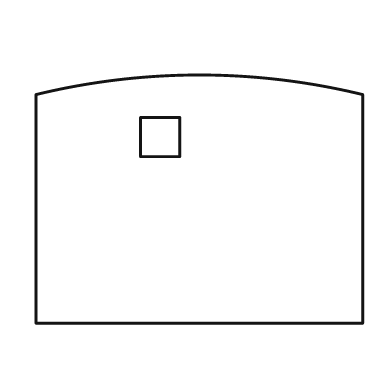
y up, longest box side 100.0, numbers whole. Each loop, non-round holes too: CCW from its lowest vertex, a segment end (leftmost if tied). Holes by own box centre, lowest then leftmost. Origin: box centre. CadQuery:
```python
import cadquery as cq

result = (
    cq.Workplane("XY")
    .moveTo(-50.0, -38.0)
    .lineTo(50.0, -38.0)
    .lineTo(50.0, 32.0)
    .threePointArc((0.0, 38.0), (-50.0, 32.0))
    .close()
    .moveTo(-18.0, 13.0)
    .lineTo(-6.0, 13.0)
    .lineTo(-6.0, 25.0)
    .lineTo(-18.0, 25.0)
    .close()
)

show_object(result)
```